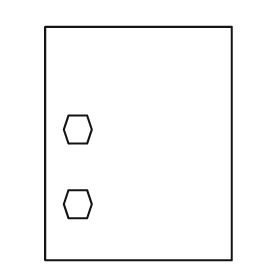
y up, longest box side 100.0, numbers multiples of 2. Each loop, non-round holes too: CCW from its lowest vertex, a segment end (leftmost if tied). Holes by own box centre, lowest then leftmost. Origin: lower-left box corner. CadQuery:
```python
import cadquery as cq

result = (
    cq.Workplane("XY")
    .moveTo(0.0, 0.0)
    .lineTo(80.0, 0.0)
    .lineTo(80.0, 100.0)
    .lineTo(0.0, 100.0)
    .close()
    .moveTo(10.0, 18.0)
    .lineTo(18.0, 18.0)
    .lineTo(20.0, 24.0)
    .lineTo(18.0, 30.0)
    .lineTo(10.0, 30.0)
    .lineTo(8.0, 24.0)
    .close()
    .moveTo(10.0, 50.0)
    .lineTo(18.0, 50.0)
    .lineTo(20.0, 56.0)
    .lineTo(18.0, 62.0)
    .lineTo(10.0, 62.0)
    .lineTo(8.0, 56.0)
    .close()
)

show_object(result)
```